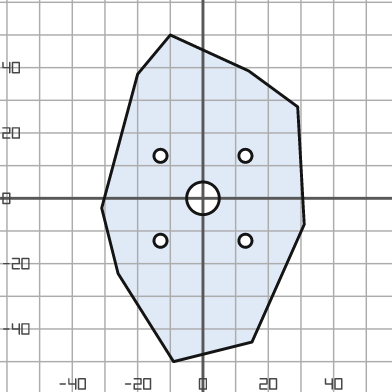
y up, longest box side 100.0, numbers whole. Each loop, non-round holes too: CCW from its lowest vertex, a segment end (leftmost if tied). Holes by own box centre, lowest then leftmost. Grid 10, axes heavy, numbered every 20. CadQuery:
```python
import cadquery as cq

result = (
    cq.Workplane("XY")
    .moveTo(-9.0, -50.0)
    .lineTo(15.0, -44.0)
    .lineTo(31.0, -8.0)
    .lineTo(29.0, 28.0)
    .lineTo(14.0, 39.0)
    .lineTo(-10.0, 50.0)
    .lineTo(-20.0, 38.0)
    .lineTo(-31.0, -3.0)
    .lineTo(-26.0, -23.0)
    .close()
    .moveTo(-13.0, -13.0)
    .circle(2.0)
    .moveTo(13.0, -13.0)
    .circle(2.0)
    .moveTo(0.0, 0.0)
    .circle(5.0)
    .moveTo(-13.0, 13.0)
    .circle(2.0)
    .moveTo(13.0, 13.0)
    .circle(2.0)
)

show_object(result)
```